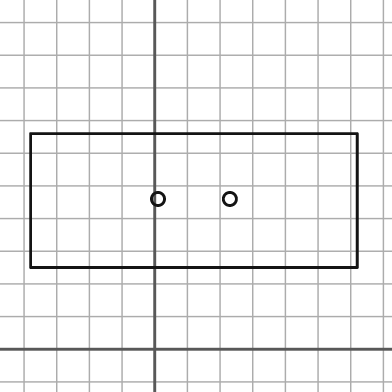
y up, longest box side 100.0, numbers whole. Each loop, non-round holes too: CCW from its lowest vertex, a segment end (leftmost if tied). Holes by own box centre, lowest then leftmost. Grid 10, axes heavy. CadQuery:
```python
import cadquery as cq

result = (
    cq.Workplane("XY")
    .moveTo(-38.0, 25.0)
    .lineTo(62.0, 25.0)
    .lineTo(62.0, 66.0)
    .lineTo(-38.0, 66.0)
    .close()
    .moveTo(1.0, 46.0)
    .circle(2.0)
    .moveTo(23.0, 46.0)
    .circle(2.0)
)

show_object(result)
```